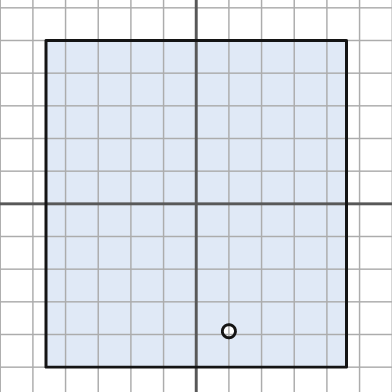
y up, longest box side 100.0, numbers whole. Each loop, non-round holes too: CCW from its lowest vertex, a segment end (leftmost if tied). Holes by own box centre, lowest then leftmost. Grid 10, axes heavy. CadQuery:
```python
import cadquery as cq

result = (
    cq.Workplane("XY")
    .moveTo(-46.0, -50.0)
    .lineTo(46.0, -50.0)
    .lineTo(46.0, 50.0)
    .lineTo(-46.0, 50.0)
    .close()
    .moveTo(10.0, -39.0)
    .circle(2.0)
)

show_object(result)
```